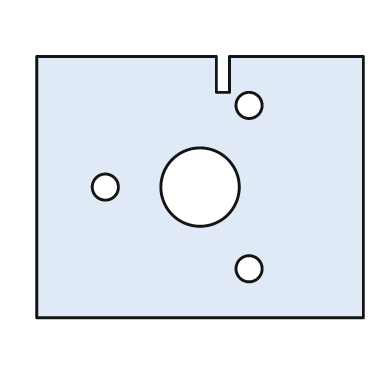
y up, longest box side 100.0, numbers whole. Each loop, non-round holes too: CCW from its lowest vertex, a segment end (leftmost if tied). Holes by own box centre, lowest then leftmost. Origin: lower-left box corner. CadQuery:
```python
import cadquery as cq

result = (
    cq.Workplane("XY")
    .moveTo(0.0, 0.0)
    .lineTo(100.0, 0.0)
    .lineTo(100.0, 80.0)
    .lineTo(59.0, 80.0)
    .lineTo(59.0, 69.0)
    .lineTo(55.0, 69.0)
    .lineTo(55.0, 80.0)
    .lineTo(0.0, 80.0)
    .close()
    .moveTo(65.0, 15.0)
    .circle(4.0)
    .moveTo(21.0, 40.0)
    .circle(4.0)
    .moveTo(50.0, 40.0)
    .circle(12.0)
    .moveTo(65.0, 65.0)
    .circle(4.0)
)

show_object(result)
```